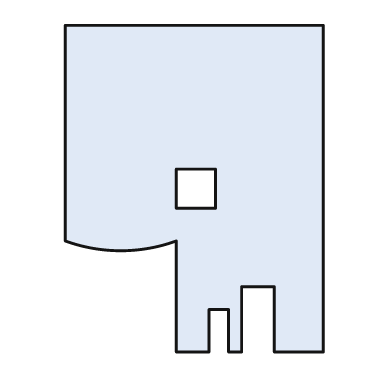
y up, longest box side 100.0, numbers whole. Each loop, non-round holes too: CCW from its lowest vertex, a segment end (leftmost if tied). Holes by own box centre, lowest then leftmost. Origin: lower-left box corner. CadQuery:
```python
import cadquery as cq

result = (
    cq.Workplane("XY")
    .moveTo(34.0, 0.0)
    .lineTo(44.0, 0.0)
    .lineTo(44.0, 13.0)
    .lineTo(50.0, 13.0)
    .lineTo(50.0, 0.0)
    .lineTo(54.0, 0.0)
    .lineTo(54.0, 20.0)
    .lineTo(64.0, 20.0)
    .lineTo(64.0, 0.0)
    .lineTo(79.0, 0.0)
    .lineTo(79.0, 100.0)
    .lineTo(0.0, 100.0)
    .lineTo(0.0, 34.0)
    .threePointArc((17.0, 31.0), (34.0, 34.0))
    .close()
    .moveTo(34.0, 44.0)
    .lineTo(46.0, 44.0)
    .lineTo(46.0, 56.0)
    .lineTo(34.0, 56.0)
    .close()
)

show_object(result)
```